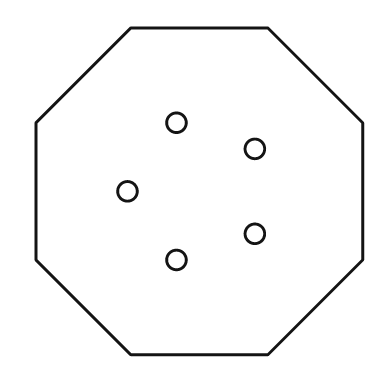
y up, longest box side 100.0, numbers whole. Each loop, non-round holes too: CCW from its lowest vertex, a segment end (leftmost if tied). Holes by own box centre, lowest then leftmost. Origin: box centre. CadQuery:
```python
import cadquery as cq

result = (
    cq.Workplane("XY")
    .moveTo(-21.0, -50.0)
    .lineTo(21.0, -50.0)
    .lineTo(50.0, -21.0)
    .lineTo(50.0, 21.0)
    .lineTo(21.0, 50.0)
    .lineTo(-21.0, 50.0)
    .lineTo(-50.0, 21.0)
    .lineTo(-50.0, -21.0)
    .close()
    .moveTo(-7.0, -21.0)
    .circle(3.0)
    .moveTo(17.0, -13.0)
    .circle(3.0)
    .moveTo(-22.0, 0.0)
    .circle(3.0)
    .moveTo(17.0, 13.0)
    .circle(3.0)
    .moveTo(-7.0, 21.0)
    .circle(3.0)
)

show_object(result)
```